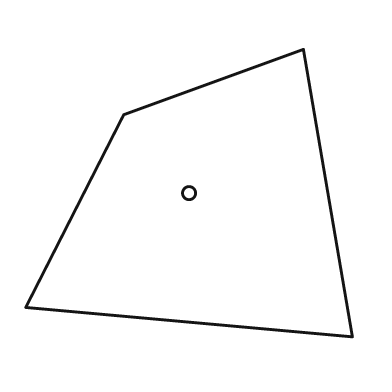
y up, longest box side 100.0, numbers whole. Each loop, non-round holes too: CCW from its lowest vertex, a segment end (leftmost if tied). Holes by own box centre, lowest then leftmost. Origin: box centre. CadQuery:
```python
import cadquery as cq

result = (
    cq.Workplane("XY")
    .moveTo(50.0, -44.0)
    .lineTo(35.0, 44.0)
    .lineTo(-20.0, 24.0)
    .lineTo(-50.0, -35.0)
    .close()
    .moveTo(0.0, 0.0)
    .circle(2.0)
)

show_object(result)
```